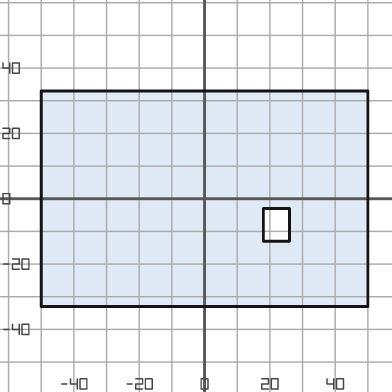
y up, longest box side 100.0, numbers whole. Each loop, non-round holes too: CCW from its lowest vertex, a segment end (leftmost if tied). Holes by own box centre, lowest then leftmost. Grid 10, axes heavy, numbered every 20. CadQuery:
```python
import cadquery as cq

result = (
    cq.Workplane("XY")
    .moveTo(-50.0, -33.0)
    .lineTo(50.0, -33.0)
    .lineTo(50.0, 33.0)
    .lineTo(-50.0, 33.0)
    .close()
    .moveTo(18.0, -13.0)
    .lineTo(26.0, -13.0)
    .lineTo(26.0, -3.0)
    .lineTo(18.0, -3.0)
    .close()
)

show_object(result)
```